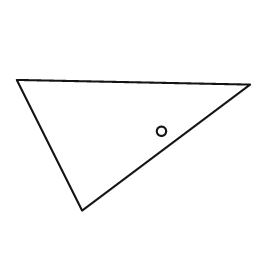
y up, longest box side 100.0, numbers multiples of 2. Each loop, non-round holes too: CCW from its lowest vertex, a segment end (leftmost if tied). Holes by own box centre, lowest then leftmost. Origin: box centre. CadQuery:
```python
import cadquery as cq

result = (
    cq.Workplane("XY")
    .moveTo(-22.0, -28.0)
    .lineTo(50.0, 26.0)
    .lineTo(-50.0, 28.0)
    .close()
    .moveTo(12.0, 6.0)
    .circle(2.0)
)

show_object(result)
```